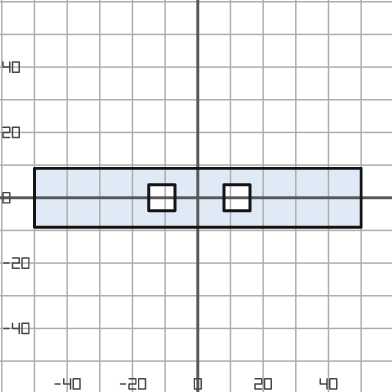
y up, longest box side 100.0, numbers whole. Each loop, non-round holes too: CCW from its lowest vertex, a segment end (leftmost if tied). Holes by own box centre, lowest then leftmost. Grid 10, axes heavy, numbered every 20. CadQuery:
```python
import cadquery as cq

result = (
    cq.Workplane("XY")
    .moveTo(-50.0, -9.0)
    .lineTo(50.0, -9.0)
    .lineTo(50.0, 9.0)
    .lineTo(-50.0, 9.0)
    .close()
    .moveTo(-15.0, -4.0)
    .lineTo(-7.0, -4.0)
    .lineTo(-7.0, 4.0)
    .lineTo(-15.0, 4.0)
    .close()
    .moveTo(8.0, -4.0)
    .lineTo(16.0, -4.0)
    .lineTo(16.0, 4.0)
    .lineTo(8.0, 4.0)
    .close()
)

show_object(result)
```